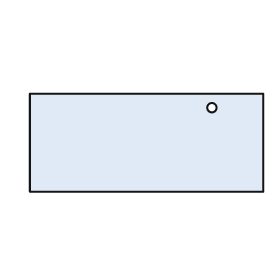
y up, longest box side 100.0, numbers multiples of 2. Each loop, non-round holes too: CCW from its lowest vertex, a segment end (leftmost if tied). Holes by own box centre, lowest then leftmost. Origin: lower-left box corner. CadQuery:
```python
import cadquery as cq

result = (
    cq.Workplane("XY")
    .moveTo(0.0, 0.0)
    .lineTo(100.0, 0.0)
    .lineTo(100.0, 42.0)
    .lineTo(0.0, 42.0)
    .close()
    .moveTo(78.0, 36.0)
    .circle(2.0)
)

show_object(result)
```